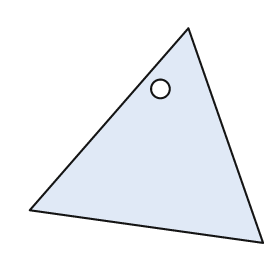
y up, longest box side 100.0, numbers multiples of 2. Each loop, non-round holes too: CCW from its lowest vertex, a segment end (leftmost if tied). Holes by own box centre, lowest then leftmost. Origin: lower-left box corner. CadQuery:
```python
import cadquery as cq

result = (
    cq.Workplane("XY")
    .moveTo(100.0, 0.0)
    .lineTo(68.0, 92.0)
    .lineTo(0.0, 14.0)
    .close()
    .moveTo(56.0, 66.0)
    .circle(4.0)
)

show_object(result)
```